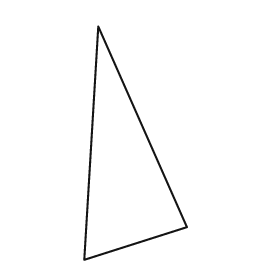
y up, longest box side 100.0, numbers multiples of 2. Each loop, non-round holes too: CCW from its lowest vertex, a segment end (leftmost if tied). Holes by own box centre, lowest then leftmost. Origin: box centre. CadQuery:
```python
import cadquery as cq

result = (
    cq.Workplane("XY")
    .moveTo(-22.0, -50.0)
    .lineTo(22.0, -36.0)
    .lineTo(-16.0, 50.0)
    .close()
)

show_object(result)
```